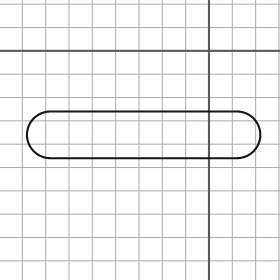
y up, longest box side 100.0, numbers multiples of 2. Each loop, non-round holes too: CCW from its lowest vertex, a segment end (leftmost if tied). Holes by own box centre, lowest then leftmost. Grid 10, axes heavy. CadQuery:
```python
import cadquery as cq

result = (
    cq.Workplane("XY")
    .moveTo(-68.0, -46.0)
    .lineTo(12.0, -46.0)
    .threePointArc((22.0, -36.0), (12.0, -26.0))
    .lineTo(-68.0, -26.0)
    .threePointArc((-78.0, -36.0), (-68.0, -46.0))
    .close()
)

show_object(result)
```